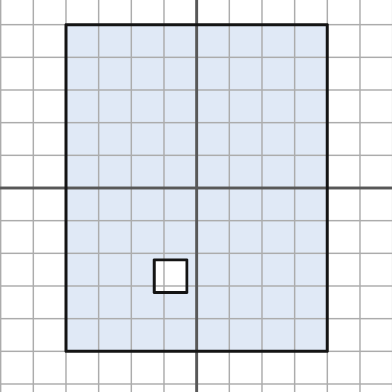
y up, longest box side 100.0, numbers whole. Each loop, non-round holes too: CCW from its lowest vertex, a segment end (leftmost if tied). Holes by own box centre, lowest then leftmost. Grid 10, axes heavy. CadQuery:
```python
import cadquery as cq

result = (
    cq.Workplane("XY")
    .moveTo(-40.0, -50.0)
    .lineTo(40.0, -50.0)
    .lineTo(40.0, 50.0)
    .lineTo(-40.0, 50.0)
    .close()
    .moveTo(-13.0, -32.0)
    .lineTo(-3.0, -32.0)
    .lineTo(-3.0, -22.0)
    .lineTo(-13.0, -22.0)
    .close()
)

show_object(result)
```